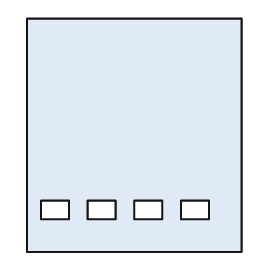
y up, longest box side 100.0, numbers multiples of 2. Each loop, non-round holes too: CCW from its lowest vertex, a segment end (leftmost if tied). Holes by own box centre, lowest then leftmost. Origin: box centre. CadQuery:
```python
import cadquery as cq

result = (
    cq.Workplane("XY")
    .moveTo(-46.0, -50.0)
    .lineTo(46.0, -50.0)
    .lineTo(46.0, 50.0)
    .lineTo(-46.0, 50.0)
    .close()
    .moveTo(-40.0, -36.0)
    .lineTo(-28.0, -36.0)
    .lineTo(-28.0, -28.0)
    .lineTo(-40.0, -28.0)
    .close()
    .moveTo(-20.0, -36.0)
    .lineTo(-8.0, -36.0)
    .lineTo(-8.0, -28.0)
    .lineTo(-20.0, -28.0)
    .close()
    .moveTo(0.0, -36.0)
    .lineTo(12.0, -36.0)
    .lineTo(12.0, -28.0)
    .lineTo(0.0, -28.0)
    .close()
    .moveTo(20.0, -36.0)
    .lineTo(32.0, -36.0)
    .lineTo(32.0, -28.0)
    .lineTo(20.0, -28.0)
    .close()
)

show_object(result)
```